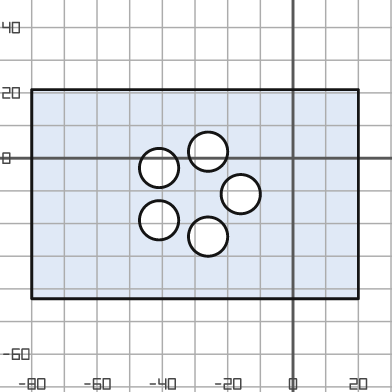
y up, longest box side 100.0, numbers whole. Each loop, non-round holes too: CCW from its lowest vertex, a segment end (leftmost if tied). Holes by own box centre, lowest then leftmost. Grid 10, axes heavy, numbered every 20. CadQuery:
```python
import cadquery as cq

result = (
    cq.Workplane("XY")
    .moveTo(-80.0, -43.0)
    .lineTo(20.0, -43.0)
    .lineTo(20.0, 21.0)
    .lineTo(-80.0, 21.0)
    .close()
    .moveTo(-26.0, -24.0)
    .circle(6.0)
    .moveTo(-41.0, -19.0)
    .circle(6.0)
    .moveTo(-16.0, -11.0)
    .circle(6.0)
    .moveTo(-41.0, -3.0)
    .circle(6.0)
    .moveTo(-26.0, 2.0)
    .circle(6.0)
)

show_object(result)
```